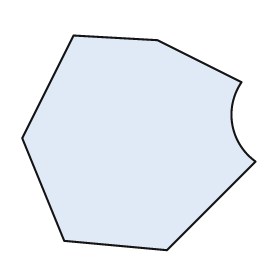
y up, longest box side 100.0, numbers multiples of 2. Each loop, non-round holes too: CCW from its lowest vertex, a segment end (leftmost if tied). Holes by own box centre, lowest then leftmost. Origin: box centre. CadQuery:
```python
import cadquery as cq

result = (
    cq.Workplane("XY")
    .moveTo(12.0, -46.0)
    .lineTo(50.0, -8.0)
    .threePointArc((40.0, 8.0), (44.0, 26.0))
    .lineTo(8.0, 44.0)
    .lineTo(-28.0, 46.0)
    .lineTo(-50.0, 2.0)
    .lineTo(-32.0, -42.0)
    .close()
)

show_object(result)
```